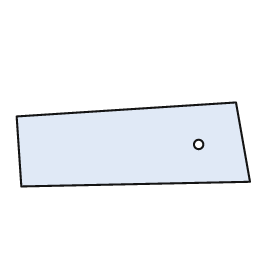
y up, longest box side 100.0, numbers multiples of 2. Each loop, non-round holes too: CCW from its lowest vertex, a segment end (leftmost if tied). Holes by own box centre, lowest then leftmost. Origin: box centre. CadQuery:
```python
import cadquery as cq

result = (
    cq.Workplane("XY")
    .moveTo(-48.0, -18.0)
    .lineTo(50.0, -16.0)
    .lineTo(44.0, 18.0)
    .lineTo(-50.0, 12.0)
    .close()
    .moveTo(28.0, 0.0)
    .circle(2.0)
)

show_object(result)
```